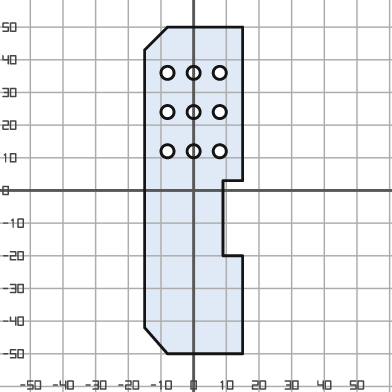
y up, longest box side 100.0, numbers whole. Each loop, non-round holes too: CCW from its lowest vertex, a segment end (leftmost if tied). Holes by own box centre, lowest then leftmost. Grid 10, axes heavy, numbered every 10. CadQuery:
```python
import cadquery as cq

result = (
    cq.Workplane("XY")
    .moveTo(-8.0, -50.0)
    .lineTo(15.0, -50.0)
    .lineTo(15.0, -20.0)
    .lineTo(9.0, -20.0)
    .lineTo(9.0, 3.0)
    .lineTo(15.0, 3.0)
    .lineTo(15.0, 50.0)
    .lineTo(-8.0, 50.0)
    .lineTo(-15.0, 43.0)
    .lineTo(-15.0, -42.0)
    .close()
    .moveTo(-8.0, 12.0)
    .circle(2.0)
    .moveTo(0.0, 12.0)
    .circle(2.0)
    .moveTo(8.0, 12.0)
    .circle(2.0)
    .moveTo(-8.0, 24.0)
    .circle(2.0)
    .moveTo(0.0, 24.0)
    .circle(2.0)
    .moveTo(8.0, 24.0)
    .circle(2.0)
    .moveTo(-8.0, 36.0)
    .circle(2.0)
    .moveTo(0.0, 36.0)
    .circle(2.0)
    .moveTo(8.0, 36.0)
    .circle(2.0)
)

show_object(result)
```